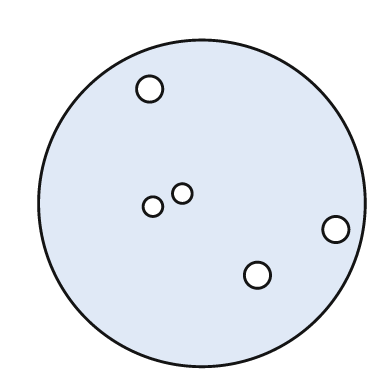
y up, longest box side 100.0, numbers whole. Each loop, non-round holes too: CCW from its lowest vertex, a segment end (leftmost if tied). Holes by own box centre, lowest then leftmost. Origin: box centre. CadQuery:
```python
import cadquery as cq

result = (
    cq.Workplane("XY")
    .moveTo(0.0, 0.0)
    .circle(50.0)
    .moveTo(17.0, -22.0)
    .circle(4.0)
    .moveTo(41.0, -8.0)
    .circle(4.0)
    .moveTo(-15.0, -1.0)
    .circle(3.0)
    .moveTo(-6.0, 3.0)
    .circle(3.0)
    .moveTo(-16.0, 35.0)
    .circle(4.0)
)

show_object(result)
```